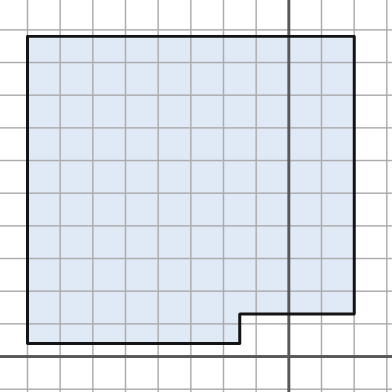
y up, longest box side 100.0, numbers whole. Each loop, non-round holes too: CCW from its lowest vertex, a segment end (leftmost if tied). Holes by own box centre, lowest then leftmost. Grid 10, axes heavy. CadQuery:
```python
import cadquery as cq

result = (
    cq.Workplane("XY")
    .moveTo(-80.0, 4.0)
    .lineTo(-15.0, 4.0)
    .lineTo(-15.0, 13.0)
    .lineTo(20.0, 13.0)
    .lineTo(20.0, 98.0)
    .lineTo(-80.0, 98.0)
    .close()
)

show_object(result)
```